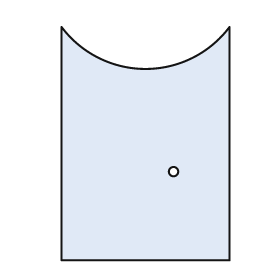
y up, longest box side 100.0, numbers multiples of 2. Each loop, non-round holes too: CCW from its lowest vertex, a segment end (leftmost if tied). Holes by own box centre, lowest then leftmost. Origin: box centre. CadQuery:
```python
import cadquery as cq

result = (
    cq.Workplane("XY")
    .moveTo(-36.0, -50.0)
    .lineTo(36.0, -50.0)
    .lineTo(36.0, 50.0)
    .threePointArc((0.0, 32.0), (-36.0, 50.0))
    .close()
    .moveTo(12.0, -12.0)
    .circle(2.0)
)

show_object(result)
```